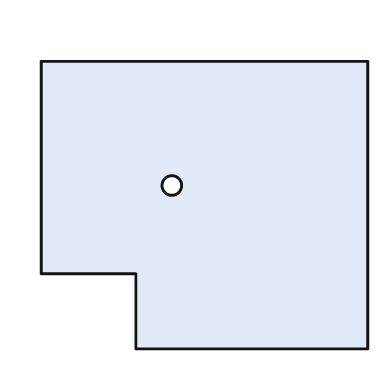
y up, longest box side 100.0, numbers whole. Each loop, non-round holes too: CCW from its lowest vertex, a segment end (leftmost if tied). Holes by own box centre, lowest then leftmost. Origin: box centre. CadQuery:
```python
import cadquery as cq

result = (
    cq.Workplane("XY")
    .moveTo(-21.0, -44.0)
    .lineTo(50.0, -44.0)
    .lineTo(50.0, 44.0)
    .lineTo(-50.0, 44.0)
    .lineTo(-50.0, -21.0)
    .lineTo(-21.0, -21.0)
    .close()
    .moveTo(-10.0, 6.0)
    .circle(3.0)
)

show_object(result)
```